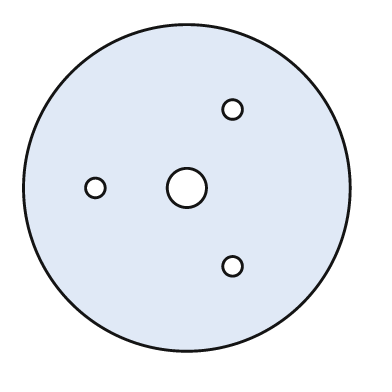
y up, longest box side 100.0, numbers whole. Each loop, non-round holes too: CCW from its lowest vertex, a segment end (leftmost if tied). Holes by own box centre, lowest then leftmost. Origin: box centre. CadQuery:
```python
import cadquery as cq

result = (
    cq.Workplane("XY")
    .moveTo(0.0, 0.0)
    .circle(50.0)
    .moveTo(14.0, -24.0)
    .circle(3.0)
    .moveTo(-28.0, 0.0)
    .circle(3.0)
    .moveTo(0.0, 0.0)
    .circle(6.0)
    .moveTo(14.0, 24.0)
    .circle(3.0)
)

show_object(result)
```